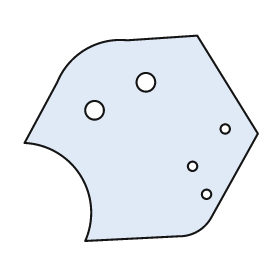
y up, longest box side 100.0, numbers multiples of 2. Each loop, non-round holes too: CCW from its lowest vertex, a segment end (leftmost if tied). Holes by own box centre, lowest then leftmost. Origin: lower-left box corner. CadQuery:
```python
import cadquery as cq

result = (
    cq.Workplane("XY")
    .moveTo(26.0, 0.0)
    .lineTo(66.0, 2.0)
    .threePointArc((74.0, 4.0), (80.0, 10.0))
    .lineTo(100.0, 46.0)
    .lineTo(74.0, 88.0)
    .lineTo(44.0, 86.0)
    .threePointArc((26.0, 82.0), (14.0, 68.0))
    .lineTo(0.0, 42.0)
    .threePointArc((24.0, 28.0), (26.0, 0.0))
    .close()
    .moveTo(78.0, 20.0)
    .circle(2.0)
    .moveTo(72.0, 32.0)
    .circle(2.0)
    .moveTo(86.0, 48.0)
    .circle(2.0)
    .moveTo(30.0, 56.0)
    .circle(4.0)
    .moveTo(52.0, 68.0)
    .circle(4.0)
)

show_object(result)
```